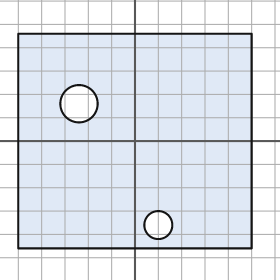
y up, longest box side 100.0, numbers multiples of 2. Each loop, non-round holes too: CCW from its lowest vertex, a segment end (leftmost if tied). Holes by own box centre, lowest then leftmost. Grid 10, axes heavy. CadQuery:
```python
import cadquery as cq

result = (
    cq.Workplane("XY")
    .moveTo(-50.0, -46.0)
    .lineTo(50.0, -46.0)
    .lineTo(50.0, 46.0)
    .lineTo(-50.0, 46.0)
    .close()
    .moveTo(10.0, -36.0)
    .circle(6.0)
    .moveTo(-24.0, 16.0)
    .circle(8.0)
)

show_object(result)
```